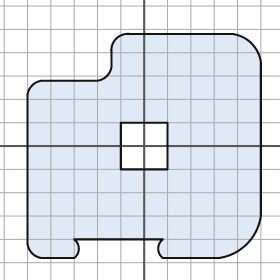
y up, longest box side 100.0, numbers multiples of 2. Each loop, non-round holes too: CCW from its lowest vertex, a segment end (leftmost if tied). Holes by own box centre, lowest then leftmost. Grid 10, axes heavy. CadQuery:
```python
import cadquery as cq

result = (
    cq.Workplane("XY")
    .moveTo(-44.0, -48.0)
    .lineTo(-30.0, -48.0)
    .threePointArc((-28.0, -44.0), (-30.0, -40.0))
    .lineTo(8.0, -40.0)
    .threePointArc((6.0, -44.0), (8.0, -48.0))
    .lineTo(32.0, -48.0)
    .threePointArc((44.0, -42.0), (50.0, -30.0))
    .lineTo(50.0, 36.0)
    .threePointArc((46.0, 44.0), (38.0, 48.0))
    .lineTo(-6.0, 48.0)
    .threePointArc((-12.0, 46.0), (-14.0, 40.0))
    .lineTo(-14.0, 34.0)
    .threePointArc((-16.0, 30.0), (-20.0, 28.0))
    .lineTo(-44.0, 28.0)
    .threePointArc((-48.0, 26.0), (-50.0, 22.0))
    .lineTo(-50.0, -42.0)
    .threePointArc((-48.0, -46.0), (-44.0, -48.0))
    .close()
    .moveTo(-10.0, -10.0)
    .lineTo(10.0, -10.0)
    .lineTo(10.0, 10.0)
    .lineTo(-10.0, 10.0)
    .close()
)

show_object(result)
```